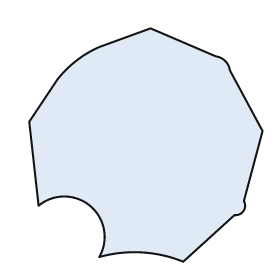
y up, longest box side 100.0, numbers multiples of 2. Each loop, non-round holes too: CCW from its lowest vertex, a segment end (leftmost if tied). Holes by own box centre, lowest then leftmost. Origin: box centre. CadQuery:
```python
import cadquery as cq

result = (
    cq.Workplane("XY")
    .moveTo(16.0, -50.0)
    .lineTo(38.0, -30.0)
    .threePointArc((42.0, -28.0), (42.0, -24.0))
    .lineTo(50.0, 6.0)
    .lineTo(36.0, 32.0)
    .threePointArc((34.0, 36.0), (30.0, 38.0))
    .lineTo(2.0, 50.0)
    .lineTo(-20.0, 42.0)
    .threePointArc((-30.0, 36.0), (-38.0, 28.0))
    .lineTo(-50.0, 10.0)
    .lineTo(-46.0, -26.0)
    .threePointArc((-24.0, -26.0), (-20.0, -48.0))
    .threePointArc((-2.0, -46.0), (16.0, -50.0))
    .close()
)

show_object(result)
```